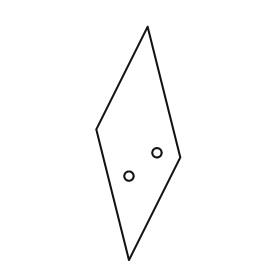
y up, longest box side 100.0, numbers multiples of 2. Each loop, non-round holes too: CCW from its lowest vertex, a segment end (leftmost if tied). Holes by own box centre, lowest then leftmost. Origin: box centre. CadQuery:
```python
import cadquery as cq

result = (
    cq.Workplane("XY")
    .moveTo(-4.0, -50.0)
    .lineTo(18.0, -6.0)
    .lineTo(4.0, 50.0)
    .lineTo(-18.0, 6.0)
    .close()
    .moveTo(-4.0, -14.0)
    .circle(2.0)
    .moveTo(8.0, -4.0)
    .circle(2.0)
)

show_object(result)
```